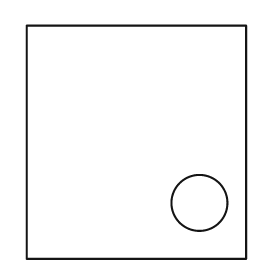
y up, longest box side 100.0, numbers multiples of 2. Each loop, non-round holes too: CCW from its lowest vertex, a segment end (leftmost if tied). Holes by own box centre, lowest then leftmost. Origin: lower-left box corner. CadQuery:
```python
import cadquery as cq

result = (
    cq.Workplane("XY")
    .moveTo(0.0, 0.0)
    .lineTo(94.0, 0.0)
    .lineTo(94.0, 100.0)
    .lineTo(0.0, 100.0)
    .close()
    .moveTo(74.0, 24.0)
    .circle(12.0)
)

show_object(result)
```